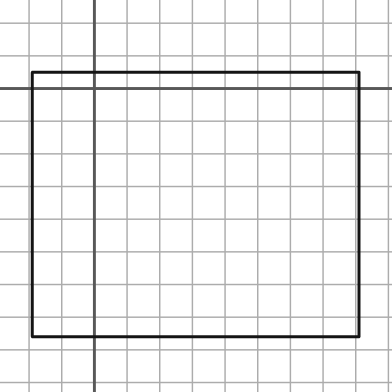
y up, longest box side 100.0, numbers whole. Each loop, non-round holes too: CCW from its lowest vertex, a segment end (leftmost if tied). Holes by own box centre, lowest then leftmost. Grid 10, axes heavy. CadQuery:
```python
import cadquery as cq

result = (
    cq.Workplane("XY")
    .moveTo(-19.0, -76.0)
    .lineTo(81.0, -76.0)
    .lineTo(81.0, 5.0)
    .lineTo(-19.0, 5.0)
    .close()
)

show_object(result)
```